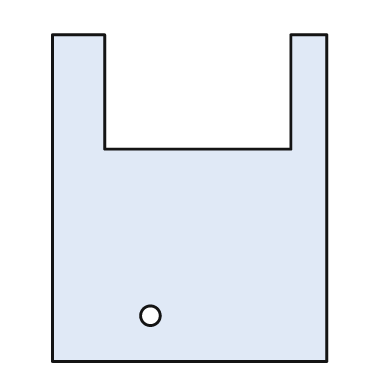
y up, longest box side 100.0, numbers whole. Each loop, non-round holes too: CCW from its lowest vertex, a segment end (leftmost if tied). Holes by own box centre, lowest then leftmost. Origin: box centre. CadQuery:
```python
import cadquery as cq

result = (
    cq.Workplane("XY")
    .moveTo(-42.0, -50.0)
    .lineTo(42.0, -50.0)
    .lineTo(42.0, 50.0)
    .lineTo(31.0, 50.0)
    .lineTo(31.0, 15.0)
    .lineTo(-26.0, 15.0)
    .lineTo(-26.0, 50.0)
    .lineTo(-42.0, 50.0)
    .close()
    .moveTo(-12.0, -36.0)
    .circle(3.0)
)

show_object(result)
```